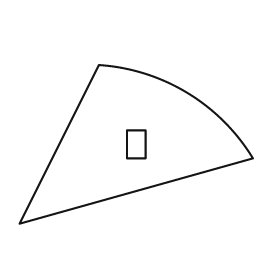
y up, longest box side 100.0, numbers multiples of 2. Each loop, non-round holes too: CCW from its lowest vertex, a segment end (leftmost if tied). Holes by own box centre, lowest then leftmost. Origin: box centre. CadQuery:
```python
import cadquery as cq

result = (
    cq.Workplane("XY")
    .moveTo(-50.0, -34.0)
    .lineTo(50.0, -6.0)
    .threePointArc((22.0, 22.0), (-16.0, 34.0))
    .close()
    .moveTo(-4.0, -6.0)
    .lineTo(4.0, -6.0)
    .lineTo(4.0, 6.0)
    .lineTo(-4.0, 6.0)
    .close()
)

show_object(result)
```